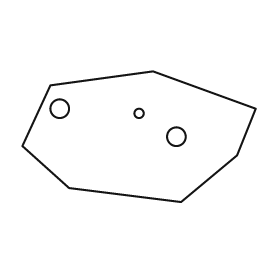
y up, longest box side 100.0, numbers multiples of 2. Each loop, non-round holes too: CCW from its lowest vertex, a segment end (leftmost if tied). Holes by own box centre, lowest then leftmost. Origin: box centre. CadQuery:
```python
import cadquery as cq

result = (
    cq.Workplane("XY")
    .moveTo(18.0, -28.0)
    .lineTo(42.0, -8.0)
    .lineTo(50.0, 12.0)
    .lineTo(6.0, 28.0)
    .lineTo(-38.0, 22.0)
    .lineTo(-50.0, -4.0)
    .lineTo(-30.0, -22.0)
    .close()
    .moveTo(16.0, 0.0)
    .circle(4.0)
    .moveTo(0.0, 10.0)
    .circle(2.0)
    .moveTo(-34.0, 12.0)
    .circle(4.0)
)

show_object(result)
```